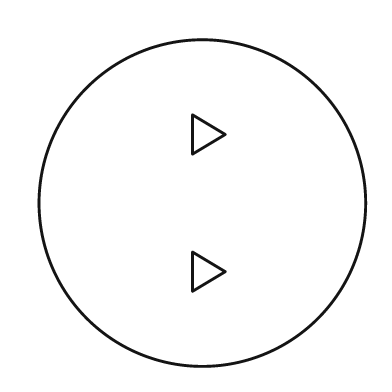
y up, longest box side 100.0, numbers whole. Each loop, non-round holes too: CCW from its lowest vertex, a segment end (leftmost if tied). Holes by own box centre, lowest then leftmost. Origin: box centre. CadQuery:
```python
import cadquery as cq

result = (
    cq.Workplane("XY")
    .moveTo(0.0, 0.0)
    .circle(50.0)
    .moveTo(-3.0, -27.0)
    .lineTo(7.0, -21.0)
    .lineTo(-3.0, -15.0)
    .close()
    .moveTo(-3.0, 15.0)
    .lineTo(7.0, 21.0)
    .lineTo(-3.0, 27.0)
    .close()
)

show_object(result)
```